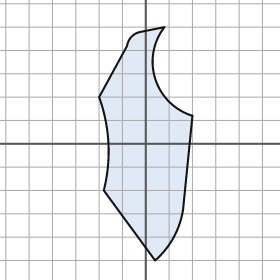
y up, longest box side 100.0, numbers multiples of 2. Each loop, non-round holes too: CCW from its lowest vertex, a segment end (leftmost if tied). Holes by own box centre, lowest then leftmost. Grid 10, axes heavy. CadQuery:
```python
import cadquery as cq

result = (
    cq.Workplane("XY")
    .moveTo(4.0, -50.0)
    .threePointArc((12.0, -40.0), (16.0, -28.0))
    .lineTo(20.0, 12.0)
    .threePointArc((4.0, 28.0), (8.0, 50.0))
    .lineTo(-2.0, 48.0)
    .threePointArc((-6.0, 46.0), (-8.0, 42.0))
    .lineTo(-20.0, 20.0)
    .threePointArc((-16.0, 0.0), (-18.0, -20.0))
    .close()
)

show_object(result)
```